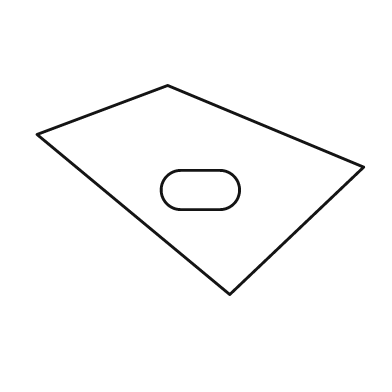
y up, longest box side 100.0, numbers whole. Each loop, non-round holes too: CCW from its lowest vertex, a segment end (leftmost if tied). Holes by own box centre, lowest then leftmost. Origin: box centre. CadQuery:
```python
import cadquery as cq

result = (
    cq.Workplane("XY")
    .moveTo(9.0, -32.0)
    .lineTo(50.0, 7.0)
    .lineTo(-10.0, 32.0)
    .lineTo(-50.0, 17.0)
    .close()
    .moveTo(-6.0, -6.0)
    .lineTo(6.0, -6.0)
    .threePointArc((12.0, 0.0), (6.0, 6.0))
    .lineTo(-6.0, 6.0)
    .threePointArc((-12.0, 0.0), (-6.0, -6.0))
    .close()
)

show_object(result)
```